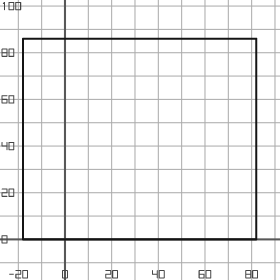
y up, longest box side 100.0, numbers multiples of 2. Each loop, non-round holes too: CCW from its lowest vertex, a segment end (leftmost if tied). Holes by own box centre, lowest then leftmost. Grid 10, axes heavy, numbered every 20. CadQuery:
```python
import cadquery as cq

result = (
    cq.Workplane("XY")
    .moveTo(-18.0, 0.0)
    .lineTo(82.0, 0.0)
    .lineTo(82.0, 86.0)
    .lineTo(-18.0, 86.0)
    .close()
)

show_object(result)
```